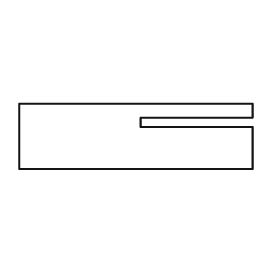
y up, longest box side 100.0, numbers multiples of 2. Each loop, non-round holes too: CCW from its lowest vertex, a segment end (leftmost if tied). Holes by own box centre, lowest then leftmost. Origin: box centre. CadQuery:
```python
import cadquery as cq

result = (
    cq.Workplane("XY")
    .moveTo(-50.0, -14.0)
    .lineTo(50.0, -14.0)
    .lineTo(50.0, 4.0)
    .lineTo(2.0, 4.0)
    .lineTo(2.0, 8.0)
    .lineTo(50.0, 8.0)
    .lineTo(50.0, 14.0)
    .lineTo(-50.0, 14.0)
    .close()
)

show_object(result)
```